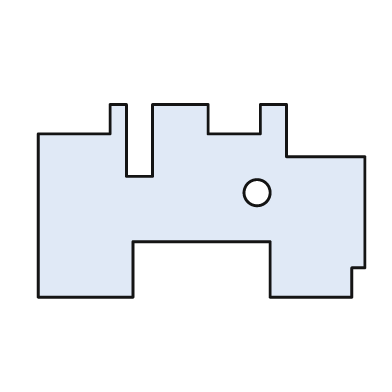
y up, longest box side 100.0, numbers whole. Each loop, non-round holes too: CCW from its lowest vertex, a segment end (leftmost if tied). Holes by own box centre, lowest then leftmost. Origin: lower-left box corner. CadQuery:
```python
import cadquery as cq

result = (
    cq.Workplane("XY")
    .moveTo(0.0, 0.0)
    .lineTo(29.0, 0.0)
    .lineTo(29.0, 17.0)
    .lineTo(71.0, 17.0)
    .lineTo(71.0, 0.0)
    .lineTo(96.0, 0.0)
    .lineTo(96.0, 9.0)
    .lineTo(100.0, 9.0)
    .lineTo(100.0, 43.0)
    .lineTo(76.0, 43.0)
    .lineTo(76.0, 59.0)
    .lineTo(68.0, 59.0)
    .lineTo(68.0, 50.0)
    .lineTo(52.0, 50.0)
    .lineTo(52.0, 59.0)
    .lineTo(35.0, 59.0)
    .lineTo(35.0, 37.0)
    .lineTo(27.0, 37.0)
    .lineTo(27.0, 59.0)
    .lineTo(22.0, 59.0)
    .lineTo(22.0, 50.0)
    .lineTo(0.0, 50.0)
    .close()
    .moveTo(67.0, 32.0)
    .circle(4.0)
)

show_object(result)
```